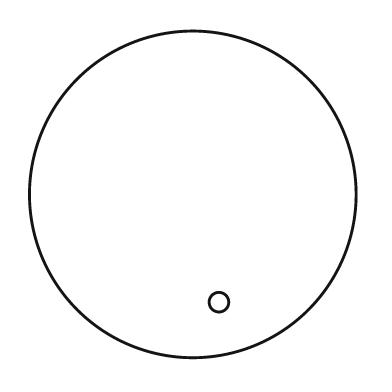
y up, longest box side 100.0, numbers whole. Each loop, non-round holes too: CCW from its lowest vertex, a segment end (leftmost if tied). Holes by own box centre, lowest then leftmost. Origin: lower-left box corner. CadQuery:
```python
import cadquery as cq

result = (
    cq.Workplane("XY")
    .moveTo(50.0, 50.0)
    .circle(50.0)
    .moveTo(58.0, 17.0)
    .circle(3.0)
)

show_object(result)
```